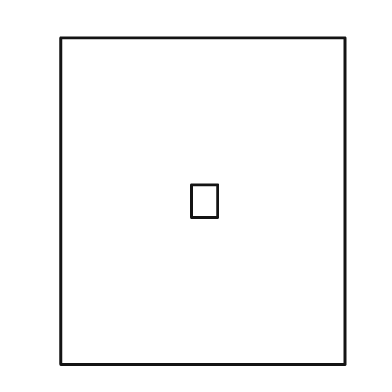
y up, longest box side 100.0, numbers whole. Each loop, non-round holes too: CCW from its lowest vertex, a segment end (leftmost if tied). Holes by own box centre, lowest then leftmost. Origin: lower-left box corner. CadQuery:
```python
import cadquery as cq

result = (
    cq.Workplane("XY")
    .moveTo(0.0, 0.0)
    .lineTo(87.0, 0.0)
    .lineTo(87.0, 100.0)
    .lineTo(0.0, 100.0)
    .close()
    .moveTo(40.0, 45.0)
    .lineTo(48.0, 45.0)
    .lineTo(48.0, 55.0)
    .lineTo(40.0, 55.0)
    .close()
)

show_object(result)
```